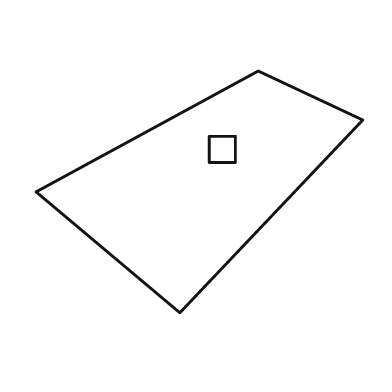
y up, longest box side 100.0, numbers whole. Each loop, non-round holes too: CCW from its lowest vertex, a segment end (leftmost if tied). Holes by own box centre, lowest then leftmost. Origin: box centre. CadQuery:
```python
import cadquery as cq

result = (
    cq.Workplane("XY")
    .moveTo(-6.0, -37.0)
    .lineTo(50.0, 22.0)
    .lineTo(18.0, 37.0)
    .lineTo(-50.0, 0.0)
    .close()
    .moveTo(3.0, 9.0)
    .lineTo(11.0, 9.0)
    .lineTo(11.0, 17.0)
    .lineTo(3.0, 17.0)
    .close()
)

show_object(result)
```